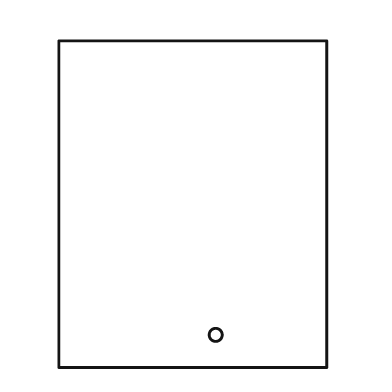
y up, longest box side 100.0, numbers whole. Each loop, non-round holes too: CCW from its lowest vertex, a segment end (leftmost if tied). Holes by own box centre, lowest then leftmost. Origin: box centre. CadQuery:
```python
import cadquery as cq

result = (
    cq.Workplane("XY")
    .moveTo(-41.0, -50.0)
    .lineTo(41.0, -50.0)
    .lineTo(41.0, 50.0)
    .lineTo(-41.0, 50.0)
    .close()
    .moveTo(7.0, -40.0)
    .circle(2.0)
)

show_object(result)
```